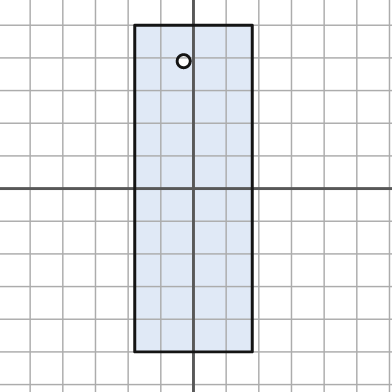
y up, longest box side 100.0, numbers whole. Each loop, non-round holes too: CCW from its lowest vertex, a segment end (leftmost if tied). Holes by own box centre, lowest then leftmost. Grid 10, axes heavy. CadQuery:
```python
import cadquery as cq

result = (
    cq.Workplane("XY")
    .moveTo(-18.0, -50.0)
    .lineTo(18.0, -50.0)
    .lineTo(18.0, 50.0)
    .lineTo(-18.0, 50.0)
    .close()
    .moveTo(-3.0, 39.0)
    .circle(2.0)
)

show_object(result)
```